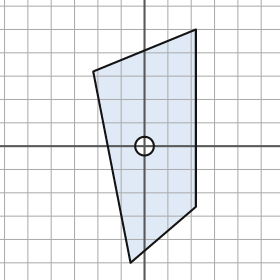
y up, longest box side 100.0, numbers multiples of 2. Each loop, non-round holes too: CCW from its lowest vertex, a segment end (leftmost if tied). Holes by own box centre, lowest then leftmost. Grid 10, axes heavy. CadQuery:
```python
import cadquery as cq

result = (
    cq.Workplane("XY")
    .moveTo(-6.0, -50.0)
    .lineTo(22.0, -26.0)
    .lineTo(22.0, 50.0)
    .lineTo(-22.0, 32.0)
    .close()
    .moveTo(0.0, 0.0)
    .circle(4.0)
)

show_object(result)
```